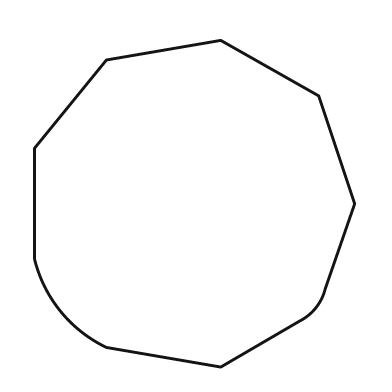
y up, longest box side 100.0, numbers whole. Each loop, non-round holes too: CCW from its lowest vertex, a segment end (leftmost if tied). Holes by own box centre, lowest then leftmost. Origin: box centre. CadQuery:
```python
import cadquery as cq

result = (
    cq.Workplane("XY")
    .moveTo(8.0, -50.0)
    .lineTo(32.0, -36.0)
    .threePointArc((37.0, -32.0), (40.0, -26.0))
    .lineTo(49.0, 0.0)
    .lineTo(38.0, 33.0)
    .lineTo(8.0, 50.0)
    .lineTo(-27.0, 44.0)
    .lineTo(-49.0, 17.0)
    .lineTo(-49.0, -17.0)
    .threePointArc((-41.0, -33.0), (-27.0, -44.0))
    .close()
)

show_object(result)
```